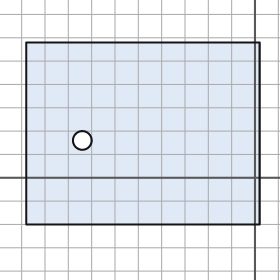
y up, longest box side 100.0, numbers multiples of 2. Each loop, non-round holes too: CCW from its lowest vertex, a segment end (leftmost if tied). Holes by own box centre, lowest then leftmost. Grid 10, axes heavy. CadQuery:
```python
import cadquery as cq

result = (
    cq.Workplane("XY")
    .moveTo(-98.0, -20.0)
    .lineTo(2.0, -20.0)
    .lineTo(2.0, 58.0)
    .lineTo(-98.0, 58.0)
    .close()
    .moveTo(-74.0, 16.0)
    .circle(4.0)
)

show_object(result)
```